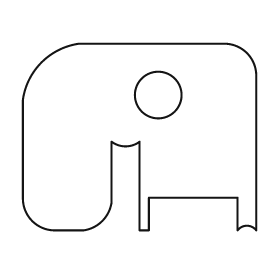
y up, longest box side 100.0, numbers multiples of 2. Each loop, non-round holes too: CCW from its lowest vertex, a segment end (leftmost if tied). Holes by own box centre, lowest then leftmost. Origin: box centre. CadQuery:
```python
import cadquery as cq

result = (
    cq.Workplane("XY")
    .moveTo(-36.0, -40.0)
    .lineTo(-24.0, -40.0)
    .threePointArc((-16.0, -36.0), (-12.0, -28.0))
    .lineTo(-12.0, -2.0)
    .threePointArc((-6.0, -4.0), (0.0, -2.0))
    .lineTo(0.0, -40.0)
    .lineTo(4.0, -40.0)
    .lineTo(4.0, -26.0)
    .lineTo(42.0, -26.0)
    .lineTo(42.0, -40.0)
    .threePointArc((46.0, -38.0), (50.0, -40.0))
    .lineTo(50.0, 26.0)
    .threePointArc((46.0, 36.0), (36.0, 40.0))
    .lineTo(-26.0, 40.0)
    .threePointArc((-42.0, 32.0), (-50.0, 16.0))
    .lineTo(-50.0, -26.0)
    .threePointArc((-46.0, -36.0), (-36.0, -40.0))
    .close()
    .moveTo(8.0, 18.0)
    .circle(10.0)
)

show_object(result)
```